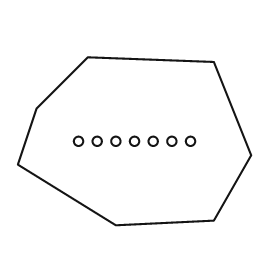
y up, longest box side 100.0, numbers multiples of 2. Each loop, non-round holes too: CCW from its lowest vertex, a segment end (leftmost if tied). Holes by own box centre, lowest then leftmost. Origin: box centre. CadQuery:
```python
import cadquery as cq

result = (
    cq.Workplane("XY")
    .moveTo(-8.0, -36.0)
    .lineTo(34.0, -34.0)
    .lineTo(50.0, -6.0)
    .lineTo(34.0, 34.0)
    .lineTo(-20.0, 36.0)
    .lineTo(-42.0, 14.0)
    .lineTo(-50.0, -10.0)
    .close()
    .moveTo(-24.0, 0.0)
    .circle(2.0)
    .moveTo(-16.0, 0.0)
    .circle(2.0)
    .moveTo(-8.0, 0.0)
    .circle(2.0)
    .moveTo(0.0, 0.0)
    .circle(2.0)
    .moveTo(8.0, 0.0)
    .circle(2.0)
    .moveTo(16.0, 0.0)
    .circle(2.0)
    .moveTo(24.0, 0.0)
    .circle(2.0)
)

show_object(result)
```